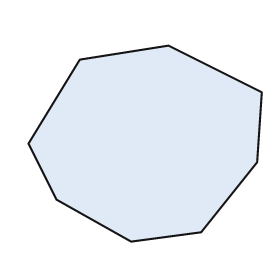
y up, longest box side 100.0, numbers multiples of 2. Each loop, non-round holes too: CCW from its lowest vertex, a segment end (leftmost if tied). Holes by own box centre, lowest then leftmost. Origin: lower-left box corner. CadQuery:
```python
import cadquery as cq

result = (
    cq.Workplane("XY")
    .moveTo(44.0, 0.0)
    .lineTo(74.0, 4.0)
    .lineTo(98.0, 34.0)
    .lineTo(100.0, 64.0)
    .lineTo(60.0, 84.0)
    .lineTo(22.0, 78.0)
    .lineTo(0.0, 42.0)
    .lineTo(12.0, 18.0)
    .close()
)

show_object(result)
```